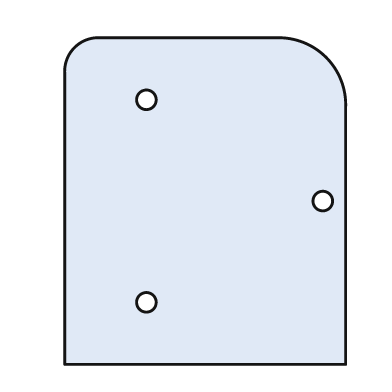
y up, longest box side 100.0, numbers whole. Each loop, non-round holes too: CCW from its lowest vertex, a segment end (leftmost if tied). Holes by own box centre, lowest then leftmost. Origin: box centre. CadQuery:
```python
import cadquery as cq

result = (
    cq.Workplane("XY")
    .moveTo(-43.0, -50.0)
    .lineTo(43.0, -50.0)
    .lineTo(43.0, 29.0)
    .threePointArc((37.0, 44.0), (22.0, 50.0))
    .lineTo(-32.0, 50.0)
    .threePointArc((-40.0, 47.0), (-43.0, 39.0))
    .close()
    .moveTo(-18.0, -31.0)
    .circle(3.0)
    .moveTo(36.0, 0.0)
    .circle(3.0)
    .moveTo(-18.0, 31.0)
    .circle(3.0)
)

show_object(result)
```